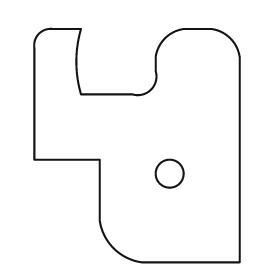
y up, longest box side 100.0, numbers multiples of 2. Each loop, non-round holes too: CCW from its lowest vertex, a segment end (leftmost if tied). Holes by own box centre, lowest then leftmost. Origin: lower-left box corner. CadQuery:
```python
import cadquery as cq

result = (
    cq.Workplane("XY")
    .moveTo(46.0, 0.0)
    .lineTo(88.0, 0.0)
    .lineTo(88.0, 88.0)
    .threePointArc((84.0, 96.0), (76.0, 100.0))
    .lineTo(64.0, 100.0)
    .threePointArc((56.0, 96.0), (52.0, 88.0))
    .lineTo(52.0, 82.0)
    .threePointArc((50.0, 74.0), (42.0, 72.0))
    .lineTo(20.0, 72.0)
    .threePointArc((18.0, 86.0), (20.0, 100.0))
    .lineTo(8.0, 100.0)
    .threePointArc((2.0, 98.0), (0.0, 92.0))
    .lineTo(0.0, 44.0)
    .lineTo(28.0, 44.0)
    .lineTo(28.0, 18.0)
    .threePointArc((34.0, 6.0), (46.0, 0.0))
    .close()
    .moveTo(58.0, 38.0)
    .circle(6.0)
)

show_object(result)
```